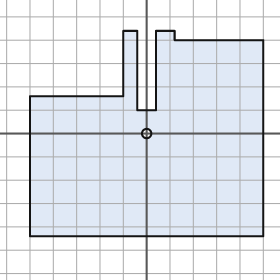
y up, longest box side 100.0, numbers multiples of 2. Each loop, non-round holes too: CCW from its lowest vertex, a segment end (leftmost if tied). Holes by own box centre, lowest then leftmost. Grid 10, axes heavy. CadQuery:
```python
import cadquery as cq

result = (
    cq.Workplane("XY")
    .moveTo(-50.0, -44.0)
    .lineTo(50.0, -44.0)
    .lineTo(50.0, 40.0)
    .lineTo(12.0, 40.0)
    .lineTo(12.0, 44.0)
    .lineTo(4.0, 44.0)
    .lineTo(4.0, 10.0)
    .lineTo(-4.0, 10.0)
    .lineTo(-4.0, 44.0)
    .lineTo(-10.0, 44.0)
    .lineTo(-10.0, 16.0)
    .lineTo(-50.0, 16.0)
    .close()
    .moveTo(0.0, 0.0)
    .circle(2.0)
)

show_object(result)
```